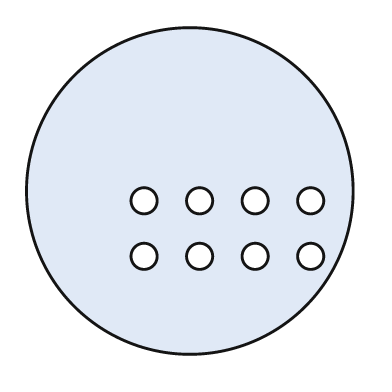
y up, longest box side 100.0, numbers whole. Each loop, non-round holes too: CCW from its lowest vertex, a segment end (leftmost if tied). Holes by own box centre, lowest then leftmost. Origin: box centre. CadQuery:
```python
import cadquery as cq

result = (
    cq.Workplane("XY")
    .moveTo(0.0, 0.0)
    .circle(50.0)
    .moveTo(-14.0, -20.0)
    .circle(4.0)
    .moveTo(3.0, -20.0)
    .circle(4.0)
    .moveTo(20.0, -20.0)
    .circle(4.0)
    .moveTo(37.0, -20.0)
    .circle(4.0)
    .moveTo(-14.0, -3.0)
    .circle(4.0)
    .moveTo(3.0, -3.0)
    .circle(4.0)
    .moveTo(20.0, -3.0)
    .circle(4.0)
    .moveTo(37.0, -3.0)
    .circle(4.0)
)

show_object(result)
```